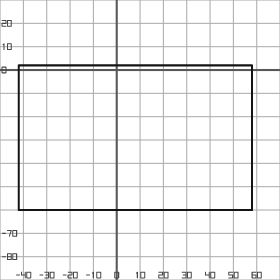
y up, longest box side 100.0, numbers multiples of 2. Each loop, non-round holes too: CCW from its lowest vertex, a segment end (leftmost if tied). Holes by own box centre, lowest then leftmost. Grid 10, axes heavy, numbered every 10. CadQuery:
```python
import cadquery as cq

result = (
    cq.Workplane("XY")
    .moveTo(-42.0, -60.0)
    .lineTo(58.0, -60.0)
    .lineTo(58.0, 2.0)
    .lineTo(-42.0, 2.0)
    .close()
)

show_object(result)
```